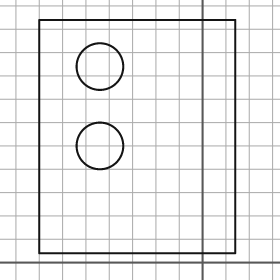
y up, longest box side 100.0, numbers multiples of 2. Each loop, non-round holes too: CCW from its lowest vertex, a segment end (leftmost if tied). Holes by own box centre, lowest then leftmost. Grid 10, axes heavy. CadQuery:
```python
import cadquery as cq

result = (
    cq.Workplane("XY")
    .moveTo(-70.0, 4.0)
    .lineTo(14.0, 4.0)
    .lineTo(14.0, 104.0)
    .lineTo(-70.0, 104.0)
    .close()
    .moveTo(-44.0, 50.0)
    .circle(10.0)
    .moveTo(-44.0, 84.0)
    .circle(10.0)
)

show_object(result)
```